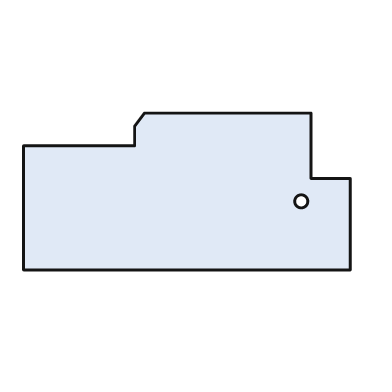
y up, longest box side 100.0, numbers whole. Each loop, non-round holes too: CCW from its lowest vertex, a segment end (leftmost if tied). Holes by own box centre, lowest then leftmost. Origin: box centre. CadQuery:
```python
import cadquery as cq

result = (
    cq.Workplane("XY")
    .moveTo(-50.0, -24.0)
    .lineTo(50.0, -24.0)
    .lineTo(50.0, 4.0)
    .lineTo(38.0, 4.0)
    .lineTo(38.0, 24.0)
    .lineTo(-13.0, 24.0)
    .lineTo(-16.0, 20.0)
    .lineTo(-16.0, 14.0)
    .lineTo(-50.0, 14.0)
    .close()
    .moveTo(35.0, -3.0)
    .circle(2.0)
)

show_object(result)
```